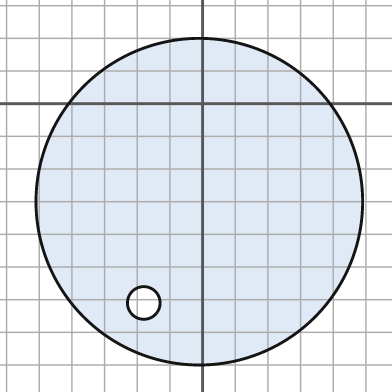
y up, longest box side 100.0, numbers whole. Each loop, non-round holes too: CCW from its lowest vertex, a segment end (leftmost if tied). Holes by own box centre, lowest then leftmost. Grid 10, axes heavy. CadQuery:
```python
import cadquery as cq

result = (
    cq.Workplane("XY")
    .moveTo(-1.0, -30.0)
    .circle(50.0)
    .moveTo(-18.0, -61.0)
    .circle(5.0)
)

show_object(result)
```